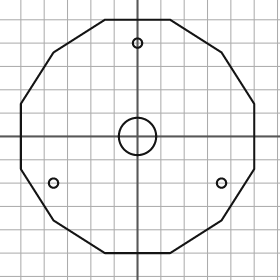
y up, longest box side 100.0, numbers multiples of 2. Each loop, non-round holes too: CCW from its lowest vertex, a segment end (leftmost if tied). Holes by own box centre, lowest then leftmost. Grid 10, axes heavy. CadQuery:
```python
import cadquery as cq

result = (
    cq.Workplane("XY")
    .moveTo(-14.0, -50.0)
    .lineTo(14.0, -50.0)
    .lineTo(36.0, -36.0)
    .lineTo(50.0, -14.0)
    .lineTo(50.0, 14.0)
    .lineTo(36.0, 36.0)
    .lineTo(14.0, 50.0)
    .lineTo(-14.0, 50.0)
    .lineTo(-36.0, 36.0)
    .lineTo(-50.0, 14.0)
    .lineTo(-50.0, -14.0)
    .lineTo(-36.0, -36.0)
    .close()
    .moveTo(-36.0, -20.0)
    .circle(2.0)
    .moveTo(36.0, -20.0)
    .circle(2.0)
    .moveTo(0.0, 0.0)
    .circle(8.0)
    .moveTo(0.0, 40.0)
    .circle(2.0)
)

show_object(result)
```